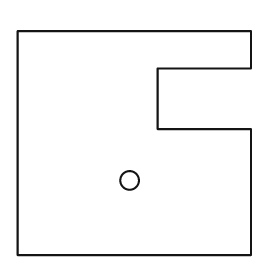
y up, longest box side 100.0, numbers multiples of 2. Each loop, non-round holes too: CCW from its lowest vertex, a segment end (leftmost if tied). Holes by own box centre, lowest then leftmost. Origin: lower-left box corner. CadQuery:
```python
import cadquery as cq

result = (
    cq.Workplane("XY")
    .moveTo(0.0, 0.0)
    .lineTo(100.0, 0.0)
    .lineTo(100.0, 54.0)
    .lineTo(60.0, 54.0)
    .lineTo(60.0, 80.0)
    .lineTo(100.0, 80.0)
    .lineTo(100.0, 96.0)
    .lineTo(0.0, 96.0)
    .close()
    .moveTo(48.0, 32.0)
    .circle(4.0)
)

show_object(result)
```